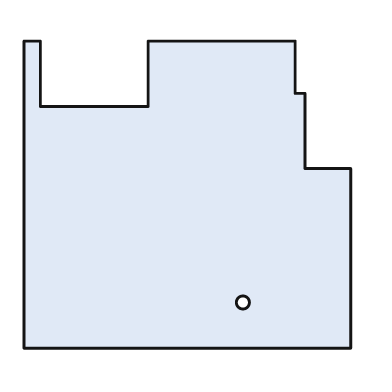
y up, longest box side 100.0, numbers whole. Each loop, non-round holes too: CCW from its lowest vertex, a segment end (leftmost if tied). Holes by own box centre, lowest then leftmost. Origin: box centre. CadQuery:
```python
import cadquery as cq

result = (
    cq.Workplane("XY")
    .moveTo(-50.0, -47.0)
    .lineTo(50.0, -47.0)
    .lineTo(50.0, 8.0)
    .lineTo(36.0, 8.0)
    .lineTo(36.0, 31.0)
    .lineTo(33.0, 31.0)
    .lineTo(33.0, 47.0)
    .lineTo(-12.0, 47.0)
    .lineTo(-12.0, 27.0)
    .lineTo(-45.0, 27.0)
    .lineTo(-45.0, 47.0)
    .lineTo(-50.0, 47.0)
    .close()
    .moveTo(17.0, -33.0)
    .circle(2.0)
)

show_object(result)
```